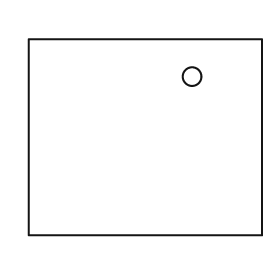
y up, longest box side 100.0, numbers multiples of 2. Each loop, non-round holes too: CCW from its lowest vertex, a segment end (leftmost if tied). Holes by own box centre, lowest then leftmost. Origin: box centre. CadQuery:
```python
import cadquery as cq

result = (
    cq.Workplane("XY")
    .moveTo(-50.0, -42.0)
    .lineTo(50.0, -42.0)
    .lineTo(50.0, 42.0)
    .lineTo(-50.0, 42.0)
    .close()
    .moveTo(20.0, 26.0)
    .circle(4.0)
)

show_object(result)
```